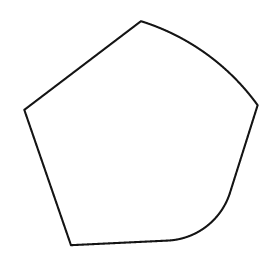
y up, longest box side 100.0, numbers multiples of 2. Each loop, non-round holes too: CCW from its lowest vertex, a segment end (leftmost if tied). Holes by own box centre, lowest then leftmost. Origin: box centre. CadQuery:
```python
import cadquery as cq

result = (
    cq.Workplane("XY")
    .moveTo(-30.0, -48.0)
    .lineTo(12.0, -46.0)
    .threePointArc((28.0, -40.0), (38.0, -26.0))
    .lineTo(50.0, 12.0)
    .threePointArc((28.0, 34.0), (0.0, 48.0))
    .lineTo(-50.0, 10.0)
    .close()
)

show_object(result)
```